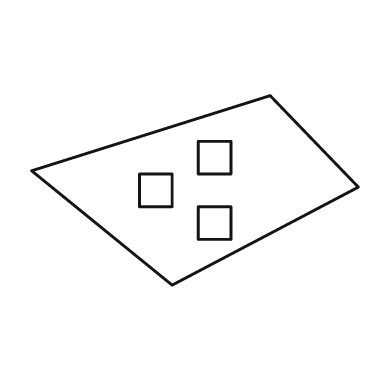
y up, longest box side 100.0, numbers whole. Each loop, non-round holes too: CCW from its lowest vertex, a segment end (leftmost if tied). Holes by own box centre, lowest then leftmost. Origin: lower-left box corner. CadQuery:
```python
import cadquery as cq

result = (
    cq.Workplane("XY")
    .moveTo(43.0, 0.0)
    .lineTo(100.0, 30.0)
    .lineTo(73.0, 58.0)
    .lineTo(0.0, 35.0)
    .close()
    .moveTo(51.0, 14.0)
    .lineTo(61.0, 14.0)
    .lineTo(61.0, 24.0)
    .lineTo(51.0, 24.0)
    .close()
    .moveTo(33.0, 24.0)
    .lineTo(43.0, 24.0)
    .lineTo(43.0, 34.0)
    .lineTo(33.0, 34.0)
    .close()
    .moveTo(51.0, 34.0)
    .lineTo(61.0, 34.0)
    .lineTo(61.0, 44.0)
    .lineTo(51.0, 44.0)
    .close()
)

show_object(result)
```